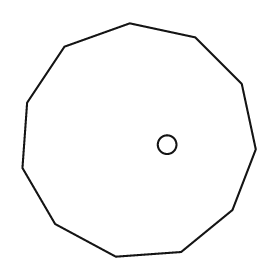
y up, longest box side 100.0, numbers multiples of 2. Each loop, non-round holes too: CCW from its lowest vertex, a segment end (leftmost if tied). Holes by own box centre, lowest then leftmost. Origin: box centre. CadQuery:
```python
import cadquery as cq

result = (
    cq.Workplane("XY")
    .moveTo(-10.0, -50.0)
    .lineTo(18.0, -48.0)
    .lineTo(40.0, -30.0)
    .lineTo(50.0, -4.0)
    .lineTo(44.0, 24.0)
    .lineTo(24.0, 44.0)
    .lineTo(-4.0, 50.0)
    .lineTo(-32.0, 40.0)
    .lineTo(-48.0, 16.0)
    .lineTo(-50.0, -12.0)
    .lineTo(-36.0, -36.0)
    .close()
    .moveTo(12.0, -2.0)
    .circle(4.0)
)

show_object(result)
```